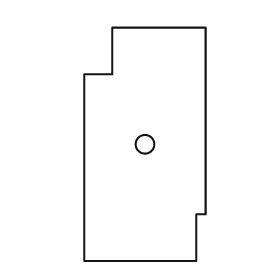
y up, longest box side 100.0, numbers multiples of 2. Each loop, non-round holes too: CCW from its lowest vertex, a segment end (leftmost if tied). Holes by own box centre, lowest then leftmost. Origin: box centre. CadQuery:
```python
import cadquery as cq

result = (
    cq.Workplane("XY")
    .moveTo(-26.0, -50.0)
    .lineTo(22.0, -50.0)
    .lineTo(22.0, -30.0)
    .lineTo(26.0, -30.0)
    .lineTo(26.0, 50.0)
    .lineTo(-14.0, 50.0)
    .lineTo(-14.0, 30.0)
    .lineTo(-26.0, 30.0)
    .close()
    .moveTo(0.0, 0.0)
    .circle(4.0)
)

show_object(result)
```